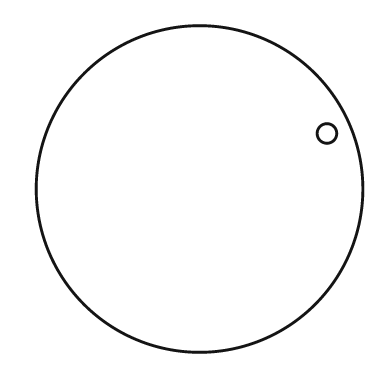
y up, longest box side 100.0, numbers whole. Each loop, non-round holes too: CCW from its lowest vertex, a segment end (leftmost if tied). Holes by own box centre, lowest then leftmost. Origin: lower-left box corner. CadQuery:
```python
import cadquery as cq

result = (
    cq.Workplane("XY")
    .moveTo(50.0, 50.0)
    .circle(50.0)
    .moveTo(89.0, 67.0)
    .circle(3.0)
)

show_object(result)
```